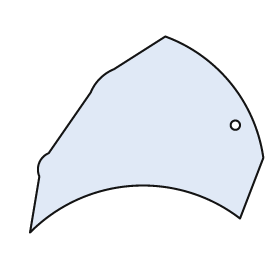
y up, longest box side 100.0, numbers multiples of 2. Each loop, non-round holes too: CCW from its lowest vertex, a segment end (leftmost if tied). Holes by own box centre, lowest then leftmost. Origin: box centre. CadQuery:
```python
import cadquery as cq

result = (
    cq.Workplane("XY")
    .moveTo(-50.0, -42.0)
    .threePointArc((-6.0, -22.0), (40.0, -36.0))
    .lineTo(50.0, -10.0)
    .threePointArc((36.0, 22.0), (8.0, 42.0))
    .lineTo(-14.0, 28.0)
    .threePointArc((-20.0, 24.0), (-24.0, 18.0))
    .lineTo(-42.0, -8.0)
    .threePointArc((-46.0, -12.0), (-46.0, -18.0))
    .close()
    .moveTo(38.0, 4.0)
    .circle(2.0)
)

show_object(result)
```